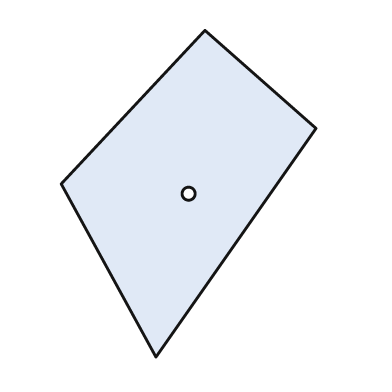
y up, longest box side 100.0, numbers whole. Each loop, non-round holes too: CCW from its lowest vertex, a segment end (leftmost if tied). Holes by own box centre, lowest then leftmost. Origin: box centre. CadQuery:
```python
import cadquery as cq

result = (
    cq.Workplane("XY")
    .moveTo(-10.0, -50.0)
    .lineTo(39.0, 20.0)
    .lineTo(5.0, 50.0)
    .lineTo(-39.0, 3.0)
    .close()
    .moveTo(0.0, 0.0)
    .circle(2.0)
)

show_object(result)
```